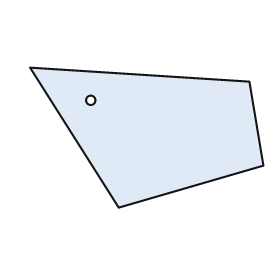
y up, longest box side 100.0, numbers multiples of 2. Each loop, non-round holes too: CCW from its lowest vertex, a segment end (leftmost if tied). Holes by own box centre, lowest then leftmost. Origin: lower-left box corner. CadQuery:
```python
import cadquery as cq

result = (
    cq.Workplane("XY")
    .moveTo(38.0, 0.0)
    .lineTo(100.0, 18.0)
    .lineTo(94.0, 54.0)
    .lineTo(0.0, 60.0)
    .close()
    .moveTo(26.0, 46.0)
    .circle(2.0)
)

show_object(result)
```